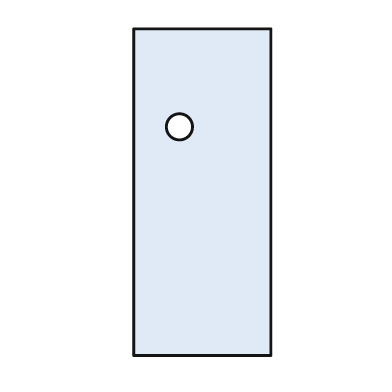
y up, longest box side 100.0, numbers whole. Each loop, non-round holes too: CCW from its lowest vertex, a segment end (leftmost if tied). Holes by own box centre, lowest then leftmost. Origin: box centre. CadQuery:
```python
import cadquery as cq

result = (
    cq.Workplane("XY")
    .moveTo(-21.0, -50.0)
    .lineTo(21.0, -50.0)
    .lineTo(21.0, 50.0)
    .lineTo(-21.0, 50.0)
    .close()
    .moveTo(-7.0, 20.0)
    .circle(4.0)
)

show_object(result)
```